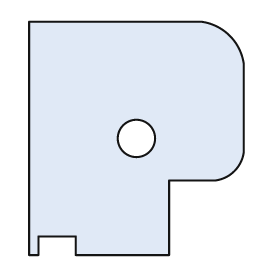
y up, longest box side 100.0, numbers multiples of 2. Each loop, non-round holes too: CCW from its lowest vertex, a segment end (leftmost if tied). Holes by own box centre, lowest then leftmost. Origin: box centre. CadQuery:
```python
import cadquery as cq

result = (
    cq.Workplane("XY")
    .moveTo(-46.0, -50.0)
    .lineTo(-42.0, -50.0)
    .lineTo(-42.0, -42.0)
    .lineTo(-26.0, -42.0)
    .lineTo(-26.0, -50.0)
    .lineTo(14.0, -50.0)
    .lineTo(14.0, -18.0)
    .lineTo(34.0, -18.0)
    .threePointArc((42.0, -14.0), (46.0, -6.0))
    .lineTo(46.0, 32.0)
    .threePointArc((40.0, 44.0), (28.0, 50.0))
    .lineTo(-46.0, 50.0)
    .close()
    .moveTo(0.0, 0.0)
    .circle(8.0)
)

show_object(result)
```